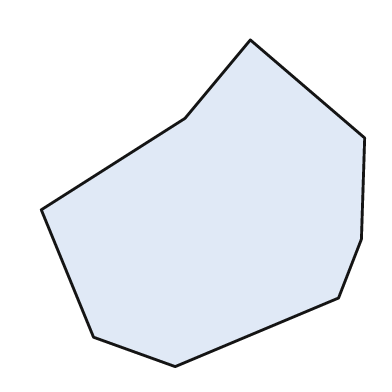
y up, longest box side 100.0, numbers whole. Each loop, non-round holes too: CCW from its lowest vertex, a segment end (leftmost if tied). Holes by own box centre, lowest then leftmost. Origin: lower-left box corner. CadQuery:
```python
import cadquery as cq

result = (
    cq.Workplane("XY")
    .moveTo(41.0, 0.0)
    .lineTo(91.0, 21.0)
    .lineTo(98.0, 39.0)
    .lineTo(99.0, 70.0)
    .lineTo(64.0, 100.0)
    .lineTo(44.0, 76.0)
    .lineTo(0.0, 48.0)
    .lineTo(16.0, 9.0)
    .close()
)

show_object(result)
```